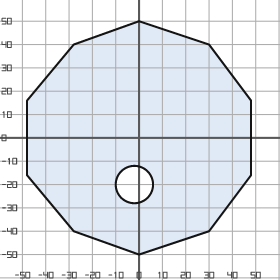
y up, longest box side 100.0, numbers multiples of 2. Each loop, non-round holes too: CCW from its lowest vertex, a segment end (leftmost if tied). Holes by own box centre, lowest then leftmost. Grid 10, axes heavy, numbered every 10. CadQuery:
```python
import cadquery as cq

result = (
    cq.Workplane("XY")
    .moveTo(0.0, -50.0)
    .lineTo(30.0, -40.0)
    .lineTo(48.0, -16.0)
    .lineTo(48.0, 16.0)
    .lineTo(30.0, 40.0)
    .lineTo(0.0, 50.0)
    .lineTo(-28.0, 40.0)
    .lineTo(-48.0, 16.0)
    .lineTo(-48.0, -16.0)
    .lineTo(-28.0, -40.0)
    .close()
    .moveTo(-2.0, -20.0)
    .circle(8.0)
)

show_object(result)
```